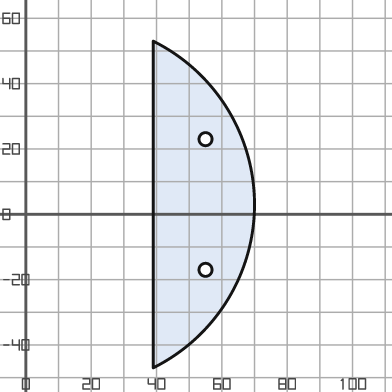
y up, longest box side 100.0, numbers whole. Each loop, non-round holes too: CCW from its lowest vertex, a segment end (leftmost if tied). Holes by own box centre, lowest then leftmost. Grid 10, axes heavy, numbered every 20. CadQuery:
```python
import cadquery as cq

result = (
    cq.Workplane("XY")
    .moveTo(39.0, -47.0)
    .threePointArc((70.0, 3.0), (39.0, 53.0))
    .close()
    .moveTo(55.0, -17.0)
    .circle(2.0)
    .moveTo(55.0, 23.0)
    .circle(2.0)
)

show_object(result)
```